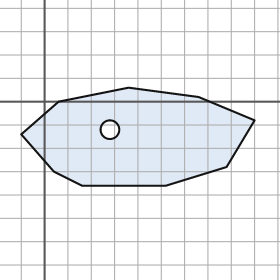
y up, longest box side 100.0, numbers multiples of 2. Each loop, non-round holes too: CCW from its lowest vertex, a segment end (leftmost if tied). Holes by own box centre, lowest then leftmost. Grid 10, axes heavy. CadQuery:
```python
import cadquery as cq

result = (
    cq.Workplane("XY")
    .moveTo(16.0, -36.0)
    .lineTo(52.0, -36.0)
    .lineTo(78.0, -28.0)
    .lineTo(90.0, -8.0)
    .lineTo(66.0, 2.0)
    .lineTo(36.0, 6.0)
    .lineTo(6.0, 0.0)
    .lineTo(-10.0, -14.0)
    .lineTo(4.0, -30.0)
    .close()
    .moveTo(28.0, -12.0)
    .circle(4.0)
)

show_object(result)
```